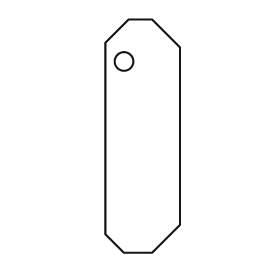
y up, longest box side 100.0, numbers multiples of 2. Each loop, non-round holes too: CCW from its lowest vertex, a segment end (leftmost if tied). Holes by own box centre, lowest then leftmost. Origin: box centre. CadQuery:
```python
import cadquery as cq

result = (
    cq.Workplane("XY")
    .moveTo(-8.0, -50.0)
    .lineTo(4.0, -50.0)
    .lineTo(16.0, -38.0)
    .lineTo(16.0, 38.0)
    .lineTo(4.0, 50.0)
    .lineTo(-6.0, 50.0)
    .lineTo(-16.0, 40.0)
    .lineTo(-16.0, -42.0)
    .close()
    .moveTo(-8.0, 32.0)
    .circle(4.0)
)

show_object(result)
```